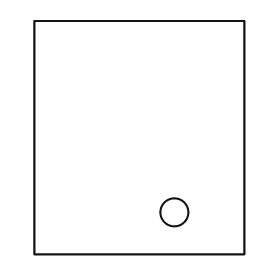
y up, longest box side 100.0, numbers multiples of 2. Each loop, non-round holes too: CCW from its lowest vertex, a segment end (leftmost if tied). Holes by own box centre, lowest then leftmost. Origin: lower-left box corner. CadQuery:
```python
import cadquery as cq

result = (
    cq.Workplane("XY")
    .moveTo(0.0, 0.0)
    .lineTo(90.0, 0.0)
    .lineTo(90.0, 100.0)
    .lineTo(0.0, 100.0)
    .close()
    .moveTo(60.0, 18.0)
    .circle(6.0)
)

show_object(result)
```